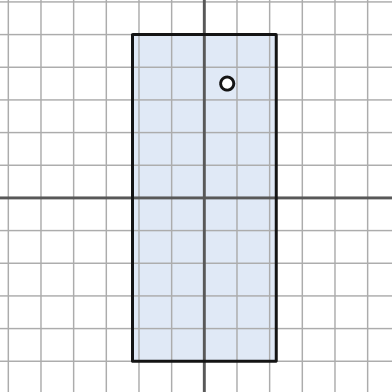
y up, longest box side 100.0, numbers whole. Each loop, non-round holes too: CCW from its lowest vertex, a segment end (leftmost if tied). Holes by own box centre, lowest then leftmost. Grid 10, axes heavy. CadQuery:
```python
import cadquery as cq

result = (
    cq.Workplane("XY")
    .moveTo(-22.0, -50.0)
    .lineTo(22.0, -50.0)
    .lineTo(22.0, 50.0)
    .lineTo(-22.0, 50.0)
    .close()
    .moveTo(7.0, 35.0)
    .circle(2.0)
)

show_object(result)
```